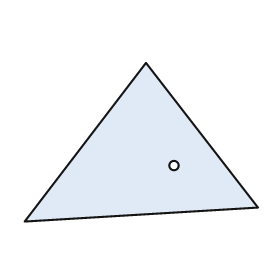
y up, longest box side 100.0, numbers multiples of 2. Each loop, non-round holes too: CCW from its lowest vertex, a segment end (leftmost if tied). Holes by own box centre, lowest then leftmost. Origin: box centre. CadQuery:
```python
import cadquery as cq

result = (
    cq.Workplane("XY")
    .moveTo(-50.0, -34.0)
    .lineTo(50.0, -28.0)
    .lineTo(2.0, 34.0)
    .close()
    .moveTo(14.0, -10.0)
    .circle(2.0)
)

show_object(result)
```